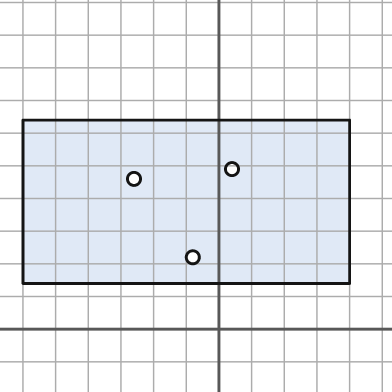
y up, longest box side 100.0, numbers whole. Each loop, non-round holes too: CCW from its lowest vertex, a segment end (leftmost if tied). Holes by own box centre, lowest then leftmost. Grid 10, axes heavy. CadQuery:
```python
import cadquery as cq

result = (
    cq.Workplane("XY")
    .moveTo(-60.0, 14.0)
    .lineTo(40.0, 14.0)
    .lineTo(40.0, 64.0)
    .lineTo(-60.0, 64.0)
    .close()
    .moveTo(-8.0, 22.0)
    .circle(2.0)
    .moveTo(-26.0, 46.0)
    .circle(2.0)
    .moveTo(4.0, 49.0)
    .circle(2.0)
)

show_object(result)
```